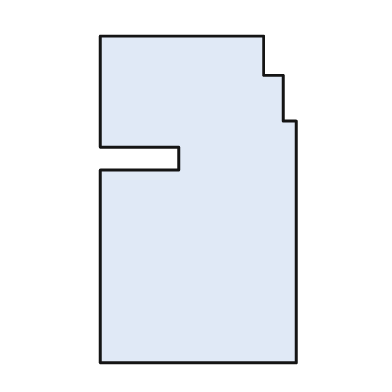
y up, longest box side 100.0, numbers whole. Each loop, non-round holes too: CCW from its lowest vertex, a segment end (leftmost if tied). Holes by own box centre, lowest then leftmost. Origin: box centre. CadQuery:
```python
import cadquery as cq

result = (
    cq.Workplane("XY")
    .moveTo(-30.0, -50.0)
    .lineTo(30.0, -50.0)
    .lineTo(30.0, 24.0)
    .lineTo(26.0, 24.0)
    .lineTo(26.0, 38.0)
    .lineTo(20.0, 38.0)
    .lineTo(20.0, 50.0)
    .lineTo(-30.0, 50.0)
    .lineTo(-30.0, 16.0)
    .lineTo(-6.0, 16.0)
    .lineTo(-6.0, 9.0)
    .lineTo(-30.0, 9.0)
    .close()
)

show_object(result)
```